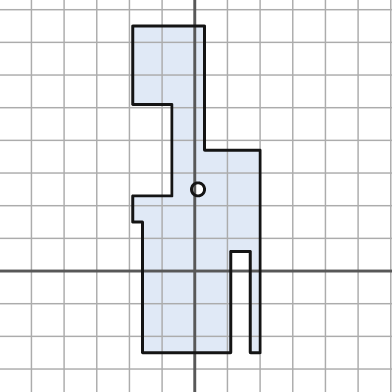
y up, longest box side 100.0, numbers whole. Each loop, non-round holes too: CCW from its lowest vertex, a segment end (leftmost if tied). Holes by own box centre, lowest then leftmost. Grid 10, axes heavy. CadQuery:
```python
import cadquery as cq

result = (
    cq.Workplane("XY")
    .moveTo(-16.0, -25.0)
    .lineTo(11.0, -25.0)
    .lineTo(11.0, 6.0)
    .lineTo(17.0, 6.0)
    .lineTo(17.0, -25.0)
    .lineTo(20.0, -25.0)
    .lineTo(20.0, 37.0)
    .lineTo(3.0, 37.0)
    .lineTo(3.0, 75.0)
    .lineTo(-19.0, 75.0)
    .lineTo(-19.0, 51.0)
    .lineTo(-7.0, 51.0)
    .lineTo(-7.0, 23.0)
    .lineTo(-19.0, 23.0)
    .lineTo(-19.0, 15.0)
    .lineTo(-16.0, 15.0)
    .close()
    .moveTo(1.0, 25.0)
    .circle(2.0)
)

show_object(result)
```